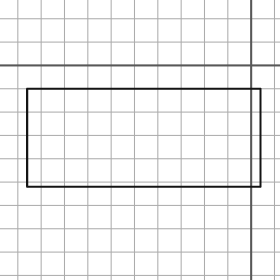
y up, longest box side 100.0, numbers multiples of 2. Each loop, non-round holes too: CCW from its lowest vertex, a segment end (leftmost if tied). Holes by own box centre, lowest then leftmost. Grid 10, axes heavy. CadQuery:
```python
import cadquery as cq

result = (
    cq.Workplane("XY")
    .moveTo(-96.0, -52.0)
    .lineTo(4.0, -52.0)
    .lineTo(4.0, -10.0)
    .lineTo(-96.0, -10.0)
    .close()
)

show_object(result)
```